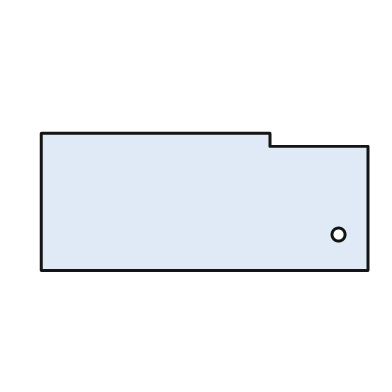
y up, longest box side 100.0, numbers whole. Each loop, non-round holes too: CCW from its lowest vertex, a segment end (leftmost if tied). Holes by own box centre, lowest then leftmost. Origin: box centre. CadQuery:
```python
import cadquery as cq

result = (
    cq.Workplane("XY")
    .moveTo(-50.0, -21.0)
    .lineTo(50.0, -21.0)
    .lineTo(50.0, 17.0)
    .lineTo(20.0, 17.0)
    .lineTo(20.0, 21.0)
    .lineTo(-50.0, 21.0)
    .close()
    .moveTo(41.0, -10.0)
    .circle(2.0)
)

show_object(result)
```